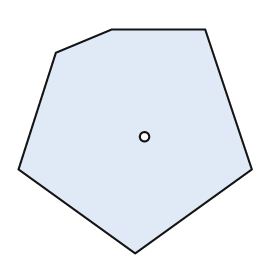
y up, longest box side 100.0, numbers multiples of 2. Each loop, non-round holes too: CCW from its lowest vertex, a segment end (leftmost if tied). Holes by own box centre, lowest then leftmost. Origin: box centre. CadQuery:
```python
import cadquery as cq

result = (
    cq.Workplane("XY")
    .moveTo(0.0, -48.0)
    .lineTo(50.0, -12.0)
    .lineTo(30.0, 48.0)
    .lineTo(-10.0, 48.0)
    .lineTo(-34.0, 38.0)
    .lineTo(-50.0, -12.0)
    .close()
    .moveTo(4.0, 2.0)
    .circle(2.0)
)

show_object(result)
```